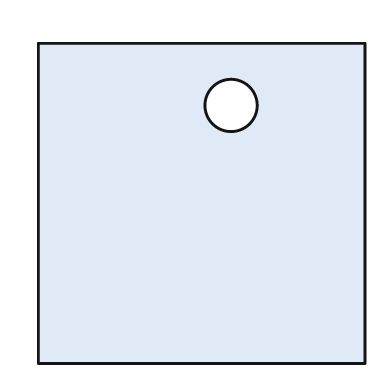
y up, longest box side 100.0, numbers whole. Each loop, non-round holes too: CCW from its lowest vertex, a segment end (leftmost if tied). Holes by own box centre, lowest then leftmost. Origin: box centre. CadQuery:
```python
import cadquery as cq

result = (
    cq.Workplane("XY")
    .moveTo(-50.0, -49.0)
    .lineTo(50.0, -49.0)
    .lineTo(50.0, 49.0)
    .lineTo(-50.0, 49.0)
    .close()
    .moveTo(9.0, 30.0)
    .circle(8.0)
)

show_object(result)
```